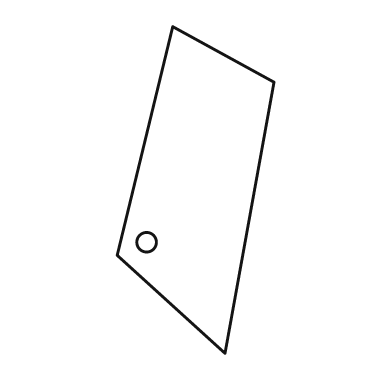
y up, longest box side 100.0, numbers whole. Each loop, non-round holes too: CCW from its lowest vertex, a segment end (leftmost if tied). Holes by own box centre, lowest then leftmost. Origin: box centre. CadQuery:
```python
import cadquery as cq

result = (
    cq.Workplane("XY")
    .moveTo(9.0, -50.0)
    .lineTo(24.0, 33.0)
    .lineTo(-7.0, 50.0)
    .lineTo(-24.0, -20.0)
    .close()
    .moveTo(-15.0, -16.0)
    .circle(3.0)
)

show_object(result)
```